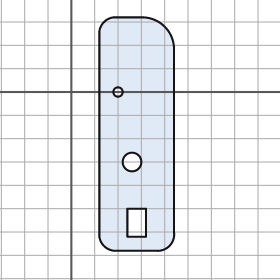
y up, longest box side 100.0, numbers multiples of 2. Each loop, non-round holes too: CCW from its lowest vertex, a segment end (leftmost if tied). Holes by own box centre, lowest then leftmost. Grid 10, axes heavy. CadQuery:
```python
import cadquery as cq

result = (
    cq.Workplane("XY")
    .moveTo(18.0, -68.0)
    .lineTo(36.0, -68.0)
    .threePointArc((42.0, -66.0), (44.0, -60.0))
    .lineTo(44.0, 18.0)
    .threePointArc((40.0, 28.0), (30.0, 32.0))
    .lineTo(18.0, 32.0)
    .threePointArc((14.0, 30.0), (12.0, 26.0))
    .lineTo(12.0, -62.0)
    .threePointArc((14.0, -66.0), (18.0, -68.0))
    .close()
    .moveTo(24.0, -62.0)
    .lineTo(32.0, -62.0)
    .lineTo(32.0, -50.0)
    .lineTo(24.0, -50.0)
    .close()
    .moveTo(26.0, -30.0)
    .circle(4.0)
    .moveTo(20.0, 0.0)
    .circle(2.0)
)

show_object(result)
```